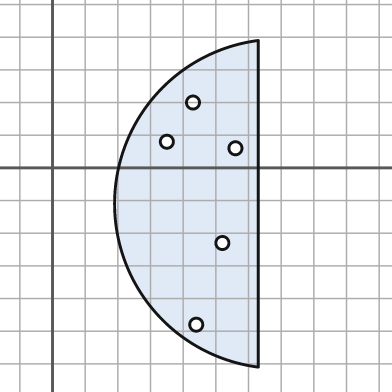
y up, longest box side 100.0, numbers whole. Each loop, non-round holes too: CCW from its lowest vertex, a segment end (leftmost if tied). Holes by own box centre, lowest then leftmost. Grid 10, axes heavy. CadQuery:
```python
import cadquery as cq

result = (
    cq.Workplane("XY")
    .moveTo(63.0, -61.0)
    .lineTo(63.0, 39.0)
    .threePointArc((19.0, -11.0), (63.0, -61.0))
    .close()
    .moveTo(44.0, -48.0)
    .circle(2.0)
    .moveTo(52.0, -23.0)
    .circle(2.0)
    .moveTo(56.0, 6.0)
    .circle(2.0)
    .moveTo(35.0, 8.0)
    .circle(2.0)
    .moveTo(43.0, 20.0)
    .circle(2.0)
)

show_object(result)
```